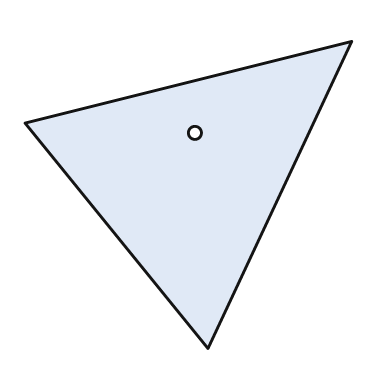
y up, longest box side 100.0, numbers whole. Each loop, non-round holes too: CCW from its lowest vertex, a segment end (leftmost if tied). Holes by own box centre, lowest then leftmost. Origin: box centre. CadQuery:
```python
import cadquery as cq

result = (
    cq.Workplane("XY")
    .moveTo(6.0, -47.0)
    .lineTo(50.0, 47.0)
    .lineTo(-50.0, 22.0)
    .close()
    .moveTo(2.0, 19.0)
    .circle(2.0)
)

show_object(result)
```